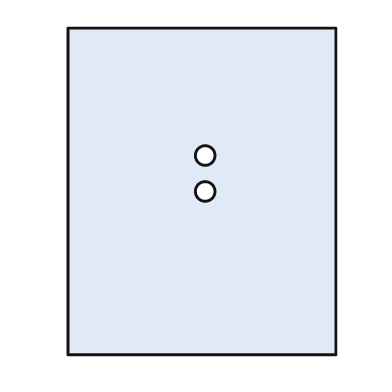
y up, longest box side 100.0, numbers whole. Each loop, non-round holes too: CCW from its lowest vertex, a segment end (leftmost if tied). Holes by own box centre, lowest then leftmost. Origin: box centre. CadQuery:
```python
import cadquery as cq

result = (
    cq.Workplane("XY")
    .moveTo(-41.0, -50.0)
    .lineTo(41.0, -50.0)
    .lineTo(41.0, 50.0)
    .lineTo(-41.0, 50.0)
    .close()
    .moveTo(1.0, 0.0)
    .circle(3.0)
    .moveTo(1.0, 11.0)
    .circle(3.0)
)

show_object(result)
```